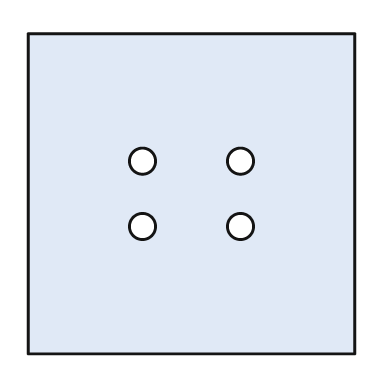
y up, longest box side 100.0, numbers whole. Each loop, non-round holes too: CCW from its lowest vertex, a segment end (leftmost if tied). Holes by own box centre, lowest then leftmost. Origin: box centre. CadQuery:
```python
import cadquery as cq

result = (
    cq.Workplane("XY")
    .moveTo(-50.0, -49.0)
    .lineTo(50.0, -49.0)
    .lineTo(50.0, 49.0)
    .lineTo(-50.0, 49.0)
    .close()
    .moveTo(-15.0, -10.0)
    .circle(4.0)
    .moveTo(15.0, -10.0)
    .circle(4.0)
    .moveTo(-15.0, 10.0)
    .circle(4.0)
    .moveTo(15.0, 10.0)
    .circle(4.0)
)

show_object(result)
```